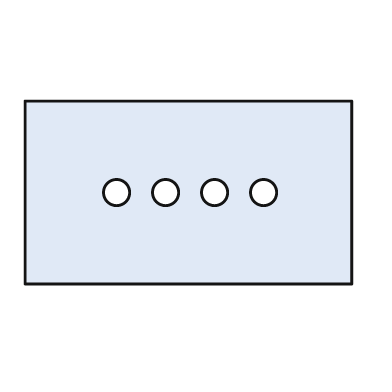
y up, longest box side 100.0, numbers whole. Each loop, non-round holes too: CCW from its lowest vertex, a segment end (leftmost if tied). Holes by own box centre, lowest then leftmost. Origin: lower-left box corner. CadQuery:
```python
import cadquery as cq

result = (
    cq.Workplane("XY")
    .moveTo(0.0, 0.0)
    .lineTo(100.0, 0.0)
    .lineTo(100.0, 56.0)
    .lineTo(0.0, 56.0)
    .close()
    .moveTo(28.0, 28.0)
    .circle(4.0)
    .moveTo(43.0, 28.0)
    .circle(4.0)
    .moveTo(58.0, 28.0)
    .circle(4.0)
    .moveTo(73.0, 28.0)
    .circle(4.0)
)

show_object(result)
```